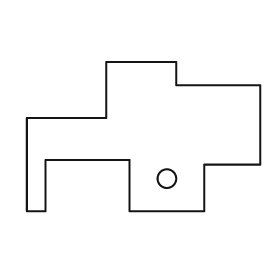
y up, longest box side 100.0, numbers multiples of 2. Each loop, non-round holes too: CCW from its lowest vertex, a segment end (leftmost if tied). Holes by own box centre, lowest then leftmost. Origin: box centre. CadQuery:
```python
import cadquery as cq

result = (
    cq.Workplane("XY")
    .moveTo(-50.0, -32.0)
    .lineTo(-42.0, -32.0)
    .lineTo(-42.0, -10.0)
    .lineTo(-6.0, -10.0)
    .lineTo(-6.0, -32.0)
    .lineTo(26.0, -32.0)
    .lineTo(26.0, -12.0)
    .lineTo(50.0, -12.0)
    .lineTo(50.0, 22.0)
    .lineTo(14.0, 22.0)
    .lineTo(14.0, 32.0)
    .lineTo(-16.0, 32.0)
    .lineTo(-16.0, 8.0)
    .lineTo(-50.0, 8.0)
    .close()
    .moveTo(10.0, -18.0)
    .circle(4.0)
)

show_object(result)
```